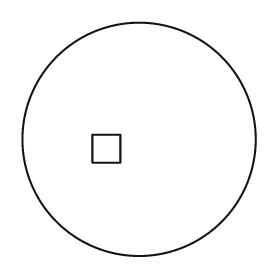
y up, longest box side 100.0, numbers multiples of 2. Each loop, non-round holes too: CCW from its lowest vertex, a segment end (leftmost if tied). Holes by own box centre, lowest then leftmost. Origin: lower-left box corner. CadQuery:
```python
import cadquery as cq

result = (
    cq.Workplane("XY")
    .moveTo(50.0, 50.0)
    .circle(50.0)
    .moveTo(30.0, 40.0)
    .lineTo(42.0, 40.0)
    .lineTo(42.0, 52.0)
    .lineTo(30.0, 52.0)
    .close()
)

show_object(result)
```